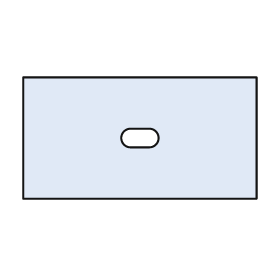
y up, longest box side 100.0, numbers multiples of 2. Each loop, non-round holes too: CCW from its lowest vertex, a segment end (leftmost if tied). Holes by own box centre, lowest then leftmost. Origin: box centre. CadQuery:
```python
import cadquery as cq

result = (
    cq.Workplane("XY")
    .moveTo(-50.0, -26.0)
    .lineTo(50.0, -26.0)
    .lineTo(50.0, 26.0)
    .lineTo(-50.0, 26.0)
    .close()
    .moveTo(-4.0, -4.0)
    .lineTo(4.0, -4.0)
    .threePointArc((8.0, 0.0), (4.0, 4.0))
    .lineTo(-4.0, 4.0)
    .threePointArc((-8.0, 0.0), (-4.0, -4.0))
    .close()
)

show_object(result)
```